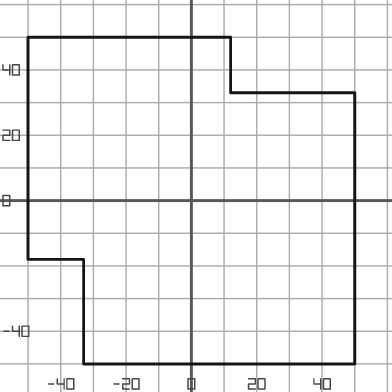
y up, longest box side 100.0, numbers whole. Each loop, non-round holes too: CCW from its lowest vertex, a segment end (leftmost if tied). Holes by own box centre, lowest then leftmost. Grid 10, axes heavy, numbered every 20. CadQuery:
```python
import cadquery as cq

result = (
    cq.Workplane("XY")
    .moveTo(-33.0, -50.0)
    .lineTo(50.0, -50.0)
    .lineTo(50.0, 33.0)
    .lineTo(12.0, 33.0)
    .lineTo(12.0, 50.0)
    .lineTo(-50.0, 50.0)
    .lineTo(-50.0, -18.0)
    .lineTo(-33.0, -18.0)
    .close()
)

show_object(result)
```